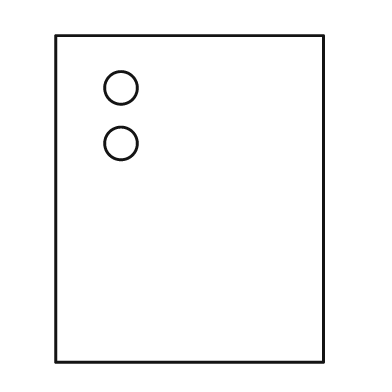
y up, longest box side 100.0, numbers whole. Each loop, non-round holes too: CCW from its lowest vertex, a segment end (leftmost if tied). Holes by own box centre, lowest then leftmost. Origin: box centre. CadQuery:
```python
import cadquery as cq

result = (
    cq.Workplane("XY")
    .moveTo(-41.0, -50.0)
    .lineTo(41.0, -50.0)
    .lineTo(41.0, 50.0)
    .lineTo(-41.0, 50.0)
    .close()
    .moveTo(-21.0, 17.0)
    .circle(5.0)
    .moveTo(-21.0, 34.0)
    .circle(5.0)
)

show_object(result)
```